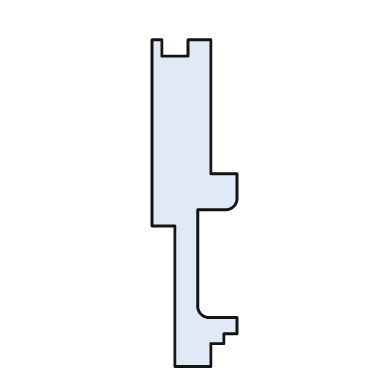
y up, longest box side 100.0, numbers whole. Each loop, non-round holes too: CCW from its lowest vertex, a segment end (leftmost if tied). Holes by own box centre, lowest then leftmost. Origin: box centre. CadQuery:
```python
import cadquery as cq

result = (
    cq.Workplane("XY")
    .moveTo(-6.0, -50.0)
    .lineTo(5.0, -50.0)
    .lineTo(5.0, -43.0)
    .lineTo(9.0, -43.0)
    .lineTo(9.0, -40.0)
    .lineTo(13.0, -40.0)
    .lineTo(13.0, -35.0)
    .lineTo(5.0, -35.0)
    .threePointArc((2.0, -34.0), (1.0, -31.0))
    .lineTo(1.0, -2.0)
    .lineTo(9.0, -2.0)
    .threePointArc((12.0, -1.0), (13.0, 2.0))
    .lineTo(13.0, 9.0)
    .lineTo(5.0, 9.0)
    .lineTo(5.0, 50.0)
    .lineTo(-2.0, 50.0)
    .lineTo(-2.0, 45.0)
    .lineTo(-10.0, 45.0)
    .lineTo(-10.0, 50.0)
    .lineTo(-13.0, 50.0)
    .lineTo(-13.0, -7.0)
    .lineTo(-6.0, -7.0)
    .close()
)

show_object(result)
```